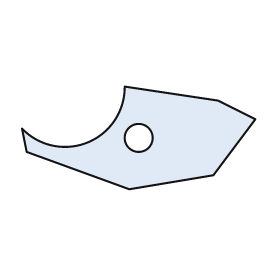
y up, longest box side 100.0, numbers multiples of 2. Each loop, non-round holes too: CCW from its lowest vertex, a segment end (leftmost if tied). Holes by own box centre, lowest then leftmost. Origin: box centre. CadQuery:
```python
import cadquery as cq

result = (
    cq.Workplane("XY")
    .moveTo(-4.0, -22.0)
    .lineTo(32.0, -16.0)
    .lineTo(50.0, 8.0)
    .lineTo(34.0, 16.0)
    .lineTo(-6.0, 22.0)
    .threePointArc((-22.0, -2.0), (-50.0, 4.0))
    .lineTo(-48.0, -6.0)
    .close()
    .moveTo(0.0, 0.0)
    .circle(6.0)
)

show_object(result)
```